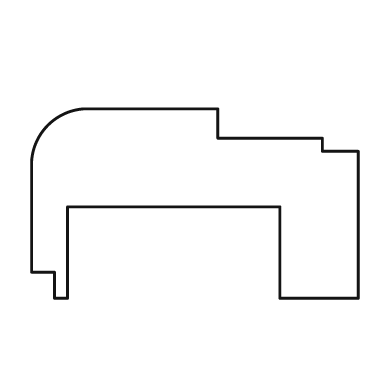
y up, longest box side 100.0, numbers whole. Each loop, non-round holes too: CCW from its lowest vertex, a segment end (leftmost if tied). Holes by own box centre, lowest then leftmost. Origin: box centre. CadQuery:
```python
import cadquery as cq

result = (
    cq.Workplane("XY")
    .moveTo(-43.0, -29.0)
    .lineTo(-39.0, -29.0)
    .lineTo(-39.0, -1.0)
    .lineTo(26.0, -1.0)
    .lineTo(26.0, -29.0)
    .lineTo(50.0, -29.0)
    .lineTo(50.0, 16.0)
    .lineTo(39.0, 16.0)
    .lineTo(39.0, 20.0)
    .lineTo(7.0, 20.0)
    .lineTo(7.0, 29.0)
    .lineTo(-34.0, 29.0)
    .threePointArc((-45.0, 24.0), (-50.0, 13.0))
    .lineTo(-50.0, -21.0)
    .lineTo(-43.0, -21.0)
    .close()
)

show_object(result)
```